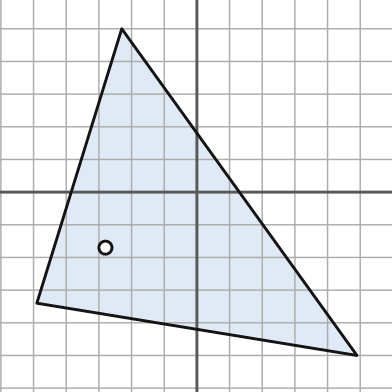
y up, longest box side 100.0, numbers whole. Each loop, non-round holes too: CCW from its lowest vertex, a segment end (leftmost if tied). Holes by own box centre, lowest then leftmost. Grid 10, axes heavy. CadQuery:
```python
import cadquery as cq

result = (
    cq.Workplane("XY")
    .moveTo(49.0, -50.0)
    .lineTo(-23.0, 50.0)
    .lineTo(-49.0, -34.0)
    .close()
    .moveTo(-28.0, -17.0)
    .circle(2.0)
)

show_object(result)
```